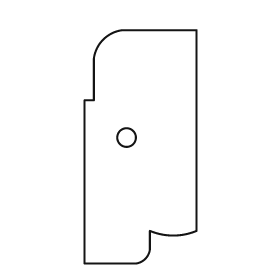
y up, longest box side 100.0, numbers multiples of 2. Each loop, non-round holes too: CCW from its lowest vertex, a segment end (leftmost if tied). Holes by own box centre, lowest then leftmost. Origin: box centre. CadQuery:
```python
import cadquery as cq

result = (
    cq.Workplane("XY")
    .moveTo(-24.0, -50.0)
    .lineTo(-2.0, -50.0)
    .threePointArc((2.0, -48.0), (4.0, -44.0))
    .lineTo(4.0, -36.0)
    .threePointArc((14.0, -38.0), (24.0, -36.0))
    .lineTo(24.0, 50.0)
    .lineTo(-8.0, 50.0)
    .threePointArc((-16.0, 46.0), (-20.0, 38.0))
    .lineTo(-20.0, 20.0)
    .lineTo(-24.0, 20.0)
    .close()
    .moveTo(-6.0, 4.0)
    .circle(4.0)
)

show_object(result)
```